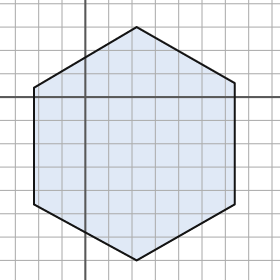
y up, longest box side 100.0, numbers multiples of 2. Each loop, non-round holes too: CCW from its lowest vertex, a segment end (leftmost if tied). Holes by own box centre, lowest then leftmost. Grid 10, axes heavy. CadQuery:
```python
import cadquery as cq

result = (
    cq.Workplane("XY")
    .moveTo(22.0, -70.0)
    .lineTo(64.0, -46.0)
    .lineTo(64.0, 6.0)
    .lineTo(22.0, 30.0)
    .lineTo(-22.0, 4.0)
    .lineTo(-22.0, -46.0)
    .close()
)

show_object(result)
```